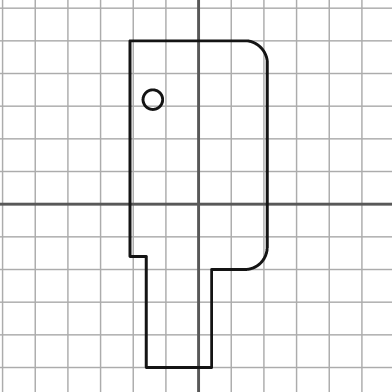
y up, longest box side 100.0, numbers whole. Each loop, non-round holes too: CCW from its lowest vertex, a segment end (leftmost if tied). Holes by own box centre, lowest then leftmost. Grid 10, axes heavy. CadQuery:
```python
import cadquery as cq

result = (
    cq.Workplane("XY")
    .moveTo(-16.0, -50.0)
    .lineTo(4.0, -50.0)
    .lineTo(4.0, -20.0)
    .lineTo(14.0, -20.0)
    .threePointArc((19.0, -18.0), (21.0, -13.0))
    .lineTo(21.0, 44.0)
    .threePointArc((19.0, 48.0), (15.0, 50.0))
    .lineTo(-21.0, 50.0)
    .lineTo(-21.0, -16.0)
    .lineTo(-16.0, -16.0)
    .close()
    .moveTo(-14.0, 32.0)
    .circle(3.0)
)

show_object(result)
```